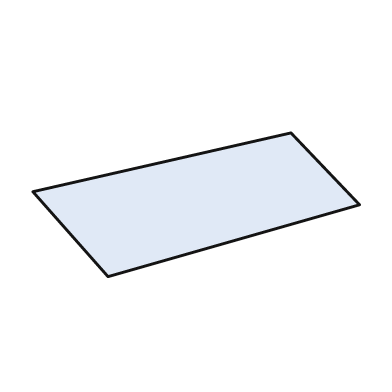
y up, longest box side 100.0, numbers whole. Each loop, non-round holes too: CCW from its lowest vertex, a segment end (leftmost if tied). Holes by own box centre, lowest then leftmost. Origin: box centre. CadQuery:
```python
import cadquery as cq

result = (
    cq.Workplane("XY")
    .moveTo(-27.0, -22.0)
    .lineTo(50.0, 0.0)
    .lineTo(29.0, 22.0)
    .lineTo(-50.0, 4.0)
    .close()
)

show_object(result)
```